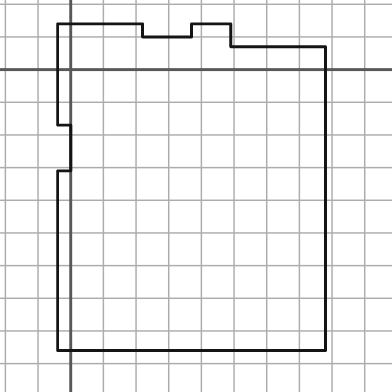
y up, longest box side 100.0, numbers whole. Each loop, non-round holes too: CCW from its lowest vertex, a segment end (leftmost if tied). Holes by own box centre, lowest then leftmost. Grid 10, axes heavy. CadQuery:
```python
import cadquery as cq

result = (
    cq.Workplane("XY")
    .moveTo(-4.0, -86.0)
    .lineTo(78.0, -86.0)
    .lineTo(78.0, 7.0)
    .lineTo(49.0, 7.0)
    .lineTo(49.0, 14.0)
    .lineTo(37.0, 14.0)
    .lineTo(37.0, 10.0)
    .lineTo(22.0, 10.0)
    .lineTo(22.0, 14.0)
    .lineTo(-4.0, 14.0)
    .lineTo(-4.0, -17.0)
    .lineTo(0.0, -17.0)
    .lineTo(0.0, -31.0)
    .lineTo(-4.0, -31.0)
    .close()
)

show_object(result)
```